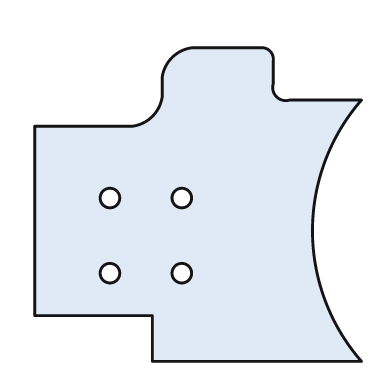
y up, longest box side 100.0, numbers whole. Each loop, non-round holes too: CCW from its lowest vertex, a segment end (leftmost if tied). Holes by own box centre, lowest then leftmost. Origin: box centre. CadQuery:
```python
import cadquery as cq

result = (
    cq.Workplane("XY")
    .moveTo(-14.0, -48.0)
    .lineTo(50.0, -48.0)
    .threePointArc((35.0, -8.0), (50.0, 32.0))
    .lineTo(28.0, 32.0)
    .threePointArc((24.0, 33.0), (23.0, 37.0))
    .lineTo(23.0, 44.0)
    .threePointArc((22.0, 47.0), (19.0, 48.0))
    .lineTo(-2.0, 48.0)
    .threePointArc((-8.0, 45.0), (-11.0, 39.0))
    .lineTo(-11.0, 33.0)
    .threePointArc((-14.0, 27.0), (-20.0, 24.0))
    .lineTo(-50.0, 24.0)
    .lineTo(-50.0, -34.0)
    .lineTo(-14.0, -34.0)
    .close()
    .moveTo(-27.0, -21.0)
    .circle(3.0)
    .moveTo(-5.0, -21.0)
    .circle(3.0)
    .moveTo(-27.0, 2.0)
    .circle(3.0)
    .moveTo(-5.0, 2.0)
    .circle(3.0)
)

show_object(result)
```